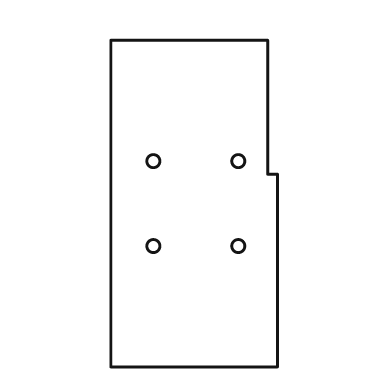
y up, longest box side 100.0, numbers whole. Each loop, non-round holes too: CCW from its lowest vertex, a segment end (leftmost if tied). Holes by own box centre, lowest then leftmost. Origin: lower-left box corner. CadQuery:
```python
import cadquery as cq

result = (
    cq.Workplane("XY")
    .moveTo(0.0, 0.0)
    .lineTo(51.0, 0.0)
    .lineTo(51.0, 59.0)
    .lineTo(48.0, 59.0)
    .lineTo(48.0, 100.0)
    .lineTo(0.0, 100.0)
    .close()
    .moveTo(13.0, 37.0)
    .circle(2.0)
    .moveTo(39.0, 37.0)
    .circle(2.0)
    .moveTo(13.0, 63.0)
    .circle(2.0)
    .moveTo(39.0, 63.0)
    .circle(2.0)
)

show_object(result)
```